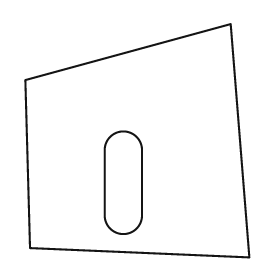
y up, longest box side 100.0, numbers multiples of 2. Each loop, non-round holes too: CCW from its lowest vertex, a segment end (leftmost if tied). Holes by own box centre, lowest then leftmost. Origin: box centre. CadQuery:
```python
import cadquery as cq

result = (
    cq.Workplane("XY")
    .moveTo(48.0, -50.0)
    .lineTo(40.0, 50.0)
    .lineTo(-48.0, 26.0)
    .lineTo(-46.0, -46.0)
    .close()
    .moveTo(-14.0, -32.0)
    .threePointArc((-6.0, -40.0), (2.0, -32.0))
    .lineTo(2.0, -4.0)
    .threePointArc((-6.0, 4.0), (-14.0, -4.0))
    .close()
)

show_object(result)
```